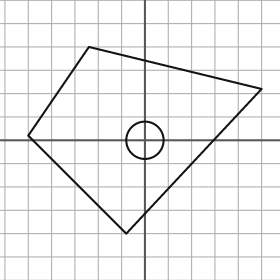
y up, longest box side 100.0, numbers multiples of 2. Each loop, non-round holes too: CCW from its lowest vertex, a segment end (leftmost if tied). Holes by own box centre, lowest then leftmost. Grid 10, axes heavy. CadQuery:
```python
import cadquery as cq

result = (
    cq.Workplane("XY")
    .moveTo(-8.0, -40.0)
    .lineTo(50.0, 22.0)
    .lineTo(-24.0, 40.0)
    .lineTo(-50.0, 2.0)
    .close()
    .moveTo(0.0, 0.0)
    .circle(8.0)
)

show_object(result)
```